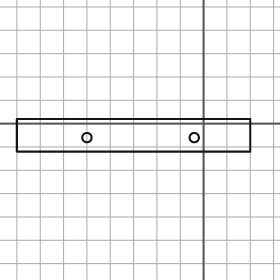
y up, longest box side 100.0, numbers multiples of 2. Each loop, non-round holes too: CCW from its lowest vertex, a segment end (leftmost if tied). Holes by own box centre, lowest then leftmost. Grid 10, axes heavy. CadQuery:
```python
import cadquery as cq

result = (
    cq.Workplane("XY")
    .moveTo(-80.0, -12.0)
    .lineTo(20.0, -12.0)
    .lineTo(20.0, 2.0)
    .lineTo(-80.0, 2.0)
    .close()
    .moveTo(-50.0, -6.0)
    .circle(2.0)
    .moveTo(-4.0, -6.0)
    .circle(2.0)
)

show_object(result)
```